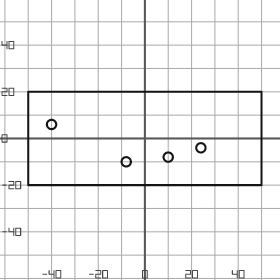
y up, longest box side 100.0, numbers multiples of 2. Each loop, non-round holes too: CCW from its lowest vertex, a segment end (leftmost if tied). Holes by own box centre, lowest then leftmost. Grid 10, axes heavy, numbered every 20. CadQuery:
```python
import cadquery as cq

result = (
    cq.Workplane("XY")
    .moveTo(-50.0, -20.0)
    .lineTo(50.0, -20.0)
    .lineTo(50.0, 20.0)
    .lineTo(-50.0, 20.0)
    .close()
    .moveTo(-8.0, -10.0)
    .circle(2.0)
    .moveTo(10.0, -8.0)
    .circle(2.0)
    .moveTo(24.0, -4.0)
    .circle(2.0)
    .moveTo(-40.0, 6.0)
    .circle(2.0)
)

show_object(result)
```